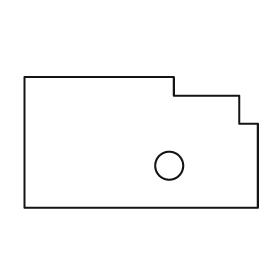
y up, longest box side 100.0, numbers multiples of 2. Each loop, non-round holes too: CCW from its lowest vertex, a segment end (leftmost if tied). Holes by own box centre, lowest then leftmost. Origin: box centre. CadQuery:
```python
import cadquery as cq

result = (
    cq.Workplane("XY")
    .moveTo(-50.0, -28.0)
    .lineTo(50.0, -28.0)
    .lineTo(50.0, 8.0)
    .lineTo(42.0, 8.0)
    .lineTo(42.0, 20.0)
    .lineTo(14.0, 20.0)
    .lineTo(14.0, 28.0)
    .lineTo(-50.0, 28.0)
    .close()
    .moveTo(12.0, -10.0)
    .circle(6.0)
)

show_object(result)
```